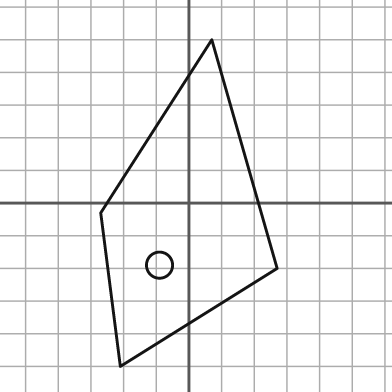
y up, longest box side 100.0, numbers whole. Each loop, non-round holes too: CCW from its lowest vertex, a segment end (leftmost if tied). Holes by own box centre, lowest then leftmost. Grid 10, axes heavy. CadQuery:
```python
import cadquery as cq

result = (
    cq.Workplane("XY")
    .moveTo(-21.0, -50.0)
    .lineTo(27.0, -20.0)
    .lineTo(7.0, 50.0)
    .lineTo(-27.0, -3.0)
    .close()
    .moveTo(-9.0, -19.0)
    .circle(4.0)
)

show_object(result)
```